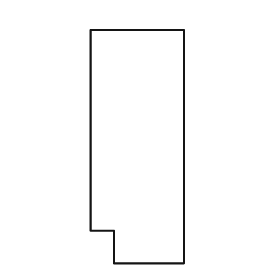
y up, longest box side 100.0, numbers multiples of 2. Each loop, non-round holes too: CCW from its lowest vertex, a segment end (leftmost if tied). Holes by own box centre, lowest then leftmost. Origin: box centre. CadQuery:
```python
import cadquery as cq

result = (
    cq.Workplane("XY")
    .moveTo(-10.0, -50.0)
    .lineTo(20.0, -50.0)
    .lineTo(20.0, 50.0)
    .lineTo(-20.0, 50.0)
    .lineTo(-20.0, -36.0)
    .lineTo(-10.0, -36.0)
    .close()
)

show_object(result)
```